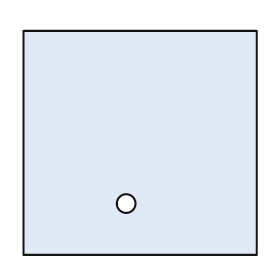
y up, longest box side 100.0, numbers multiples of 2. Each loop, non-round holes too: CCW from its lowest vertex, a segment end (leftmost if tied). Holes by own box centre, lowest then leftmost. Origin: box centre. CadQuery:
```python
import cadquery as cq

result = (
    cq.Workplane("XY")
    .moveTo(-50.0, -48.0)
    .lineTo(50.0, -48.0)
    .lineTo(50.0, 48.0)
    .lineTo(-50.0, 48.0)
    .close()
    .moveTo(-6.0, -26.0)
    .circle(4.0)
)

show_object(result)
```